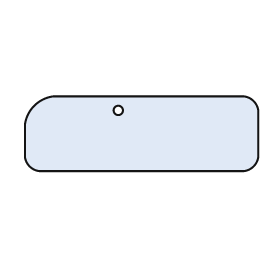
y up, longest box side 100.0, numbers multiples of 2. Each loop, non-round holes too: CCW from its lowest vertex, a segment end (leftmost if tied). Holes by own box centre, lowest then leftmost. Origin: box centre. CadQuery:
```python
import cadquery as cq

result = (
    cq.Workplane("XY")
    .moveTo(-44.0, -16.0)
    .lineTo(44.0, -16.0)
    .threePointArc((48.0, -14.0), (50.0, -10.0))
    .lineTo(50.0, 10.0)
    .threePointArc((48.0, 14.0), (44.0, 16.0))
    .lineTo(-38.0, 16.0)
    .threePointArc((-46.0, 12.0), (-50.0, 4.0))
    .lineTo(-50.0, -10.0)
    .threePointArc((-48.0, -14.0), (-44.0, -16.0))
    .close()
    .moveTo(-10.0, 10.0)
    .circle(2.0)
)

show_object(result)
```